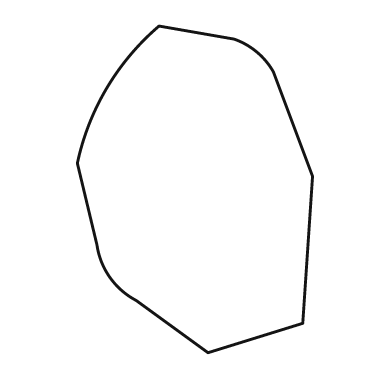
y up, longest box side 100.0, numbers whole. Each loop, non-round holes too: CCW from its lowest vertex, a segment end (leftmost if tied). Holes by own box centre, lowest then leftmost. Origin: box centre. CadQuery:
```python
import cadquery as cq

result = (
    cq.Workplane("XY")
    .moveTo(4.0, -50.0)
    .lineTo(33.0, -41.0)
    .lineTo(36.0, 4.0)
    .lineTo(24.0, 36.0)
    .threePointArc((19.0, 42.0), (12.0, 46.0))
    .lineTo(-11.0, 50.0)
    .threePointArc((-27.0, 31.0), (-36.0, 8.0))
    .lineTo(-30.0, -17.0)
    .threePointArc((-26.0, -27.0), (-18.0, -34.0))
    .close()
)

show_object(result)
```